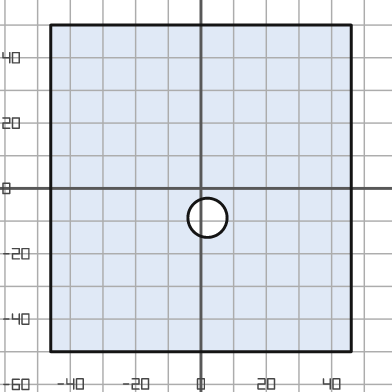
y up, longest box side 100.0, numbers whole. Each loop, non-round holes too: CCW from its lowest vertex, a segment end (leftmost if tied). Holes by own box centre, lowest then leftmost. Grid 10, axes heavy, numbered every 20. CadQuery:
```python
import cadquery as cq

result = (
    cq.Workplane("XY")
    .moveTo(-46.0, -50.0)
    .lineTo(46.0, -50.0)
    .lineTo(46.0, 50.0)
    .lineTo(-46.0, 50.0)
    .close()
    .moveTo(2.0, -9.0)
    .circle(6.0)
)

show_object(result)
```